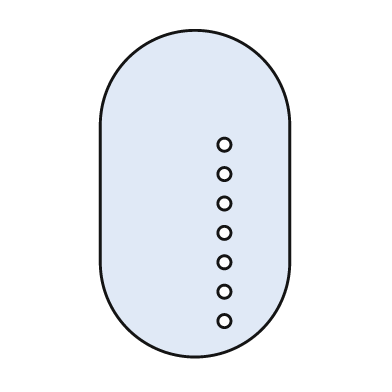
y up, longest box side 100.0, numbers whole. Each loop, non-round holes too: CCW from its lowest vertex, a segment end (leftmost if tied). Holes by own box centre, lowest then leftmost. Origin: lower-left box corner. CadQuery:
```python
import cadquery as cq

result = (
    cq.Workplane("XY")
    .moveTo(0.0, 29.0)
    .threePointArc((29.0, 0.0), (58.0, 29.0))
    .lineTo(58.0, 71.0)
    .threePointArc((29.0, 100.0), (0.0, 71.0))
    .close()
    .moveTo(38.0, 11.0)
    .circle(2.0)
    .moveTo(38.0, 20.0)
    .circle(2.0)
    .moveTo(38.0, 29.0)
    .circle(2.0)
    .moveTo(38.0, 38.0)
    .circle(2.0)
    .moveTo(38.0, 47.0)
    .circle(2.0)
    .moveTo(38.0, 56.0)
    .circle(2.0)
    .moveTo(38.0, 65.0)
    .circle(2.0)
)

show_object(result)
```